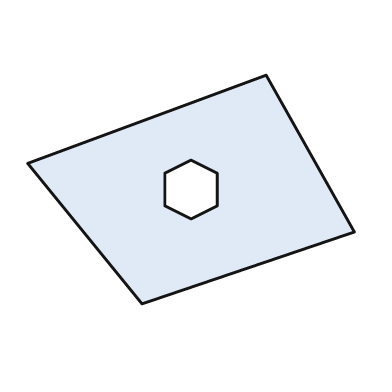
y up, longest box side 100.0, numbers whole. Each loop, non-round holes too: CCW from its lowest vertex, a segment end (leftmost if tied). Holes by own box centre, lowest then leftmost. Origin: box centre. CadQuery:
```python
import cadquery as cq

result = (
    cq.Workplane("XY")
    .moveTo(-15.0, -35.0)
    .lineTo(50.0, -13.0)
    .lineTo(23.0, 35.0)
    .lineTo(-50.0, 8.0)
    .close()
    .moveTo(0.0, -9.0)
    .lineTo(8.0, -5.0)
    .lineTo(8.0, 5.0)
    .lineTo(0.0, 9.0)
    .lineTo(-8.0, 5.0)
    .lineTo(-8.0, -5.0)
    .close()
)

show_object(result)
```